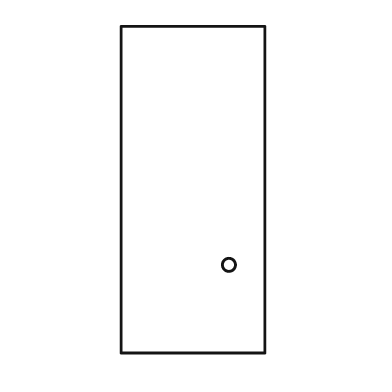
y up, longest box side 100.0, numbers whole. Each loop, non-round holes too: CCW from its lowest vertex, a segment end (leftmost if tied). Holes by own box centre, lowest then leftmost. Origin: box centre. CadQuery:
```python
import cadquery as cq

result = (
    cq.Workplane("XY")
    .moveTo(-22.0, -50.0)
    .lineTo(22.0, -50.0)
    .lineTo(22.0, 50.0)
    .lineTo(-22.0, 50.0)
    .close()
    .moveTo(11.0, -23.0)
    .circle(2.0)
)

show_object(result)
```